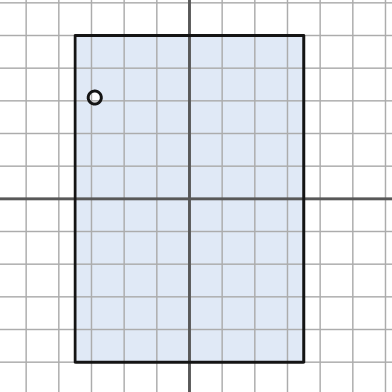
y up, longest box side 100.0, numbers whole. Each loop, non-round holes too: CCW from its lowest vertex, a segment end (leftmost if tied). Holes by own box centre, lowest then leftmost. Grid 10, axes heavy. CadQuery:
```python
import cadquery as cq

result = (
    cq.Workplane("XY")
    .moveTo(-35.0, -50.0)
    .lineTo(35.0, -50.0)
    .lineTo(35.0, 50.0)
    .lineTo(-35.0, 50.0)
    .close()
    .moveTo(-29.0, 31.0)
    .circle(2.0)
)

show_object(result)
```